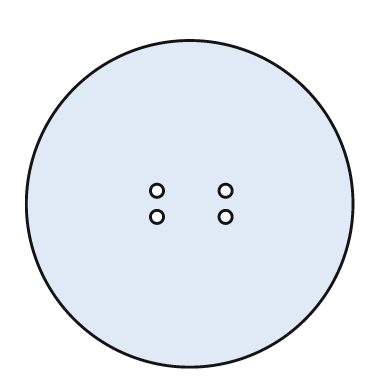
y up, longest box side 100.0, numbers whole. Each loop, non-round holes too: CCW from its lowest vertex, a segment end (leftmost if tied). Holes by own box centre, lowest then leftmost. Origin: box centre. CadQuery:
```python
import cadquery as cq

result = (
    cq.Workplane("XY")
    .moveTo(0.0, 0.0)
    .circle(50.0)
    .moveTo(-10.0, -4.0)
    .circle(2.0)
    .moveTo(11.0, -4.0)
    .circle(2.0)
    .moveTo(-10.0, 4.0)
    .circle(2.0)
    .moveTo(11.0, 4.0)
    .circle(2.0)
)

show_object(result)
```